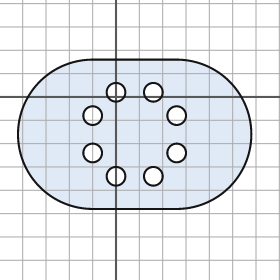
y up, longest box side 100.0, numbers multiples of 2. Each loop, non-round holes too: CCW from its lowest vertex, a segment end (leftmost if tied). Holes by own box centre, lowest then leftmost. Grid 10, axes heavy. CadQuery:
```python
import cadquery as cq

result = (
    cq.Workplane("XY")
    .moveTo(-10.0, -48.0)
    .lineTo(26.0, -48.0)
    .threePointArc((58.0, -16.0), (26.0, 16.0))
    .lineTo(-10.0, 16.0)
    .threePointArc((-42.0, -16.0), (-10.0, -48.0))
    .close()
    .moveTo(0.0, -34.0)
    .circle(4.0)
    .moveTo(16.0, -34.0)
    .circle(4.0)
    .moveTo(-10.0, -24.0)
    .circle(4.0)
    .moveTo(26.0, -24.0)
    .circle(4.0)
    .moveTo(-10.0, -8.0)
    .circle(4.0)
    .moveTo(26.0, -8.0)
    .circle(4.0)
    .moveTo(0.0, 2.0)
    .circle(4.0)
    .moveTo(16.0, 2.0)
    .circle(4.0)
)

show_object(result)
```